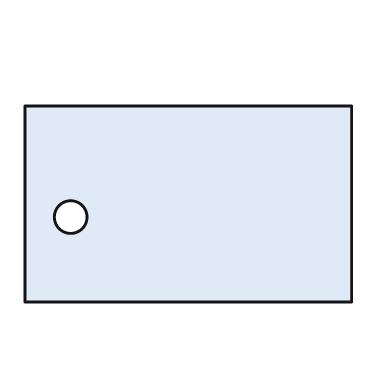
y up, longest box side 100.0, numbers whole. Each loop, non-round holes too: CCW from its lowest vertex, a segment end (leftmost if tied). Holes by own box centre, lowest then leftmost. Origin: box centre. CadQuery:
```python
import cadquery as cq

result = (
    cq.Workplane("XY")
    .moveTo(-50.0, -30.0)
    .lineTo(50.0, -30.0)
    .lineTo(50.0, 30.0)
    .lineTo(-50.0, 30.0)
    .close()
    .moveTo(-36.0, -4.0)
    .circle(5.0)
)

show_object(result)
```